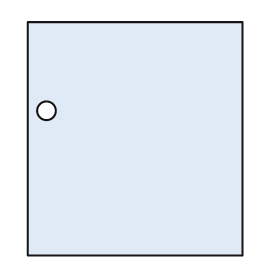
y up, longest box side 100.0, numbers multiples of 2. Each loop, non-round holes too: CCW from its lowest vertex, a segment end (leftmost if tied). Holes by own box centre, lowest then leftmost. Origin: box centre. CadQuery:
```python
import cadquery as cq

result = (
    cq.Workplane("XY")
    .moveTo(-46.0, -50.0)
    .lineTo(46.0, -50.0)
    .lineTo(46.0, 50.0)
    .lineTo(-46.0, 50.0)
    .close()
    .moveTo(-38.0, 12.0)
    .circle(4.0)
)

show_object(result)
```